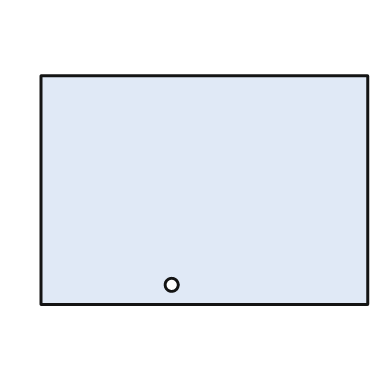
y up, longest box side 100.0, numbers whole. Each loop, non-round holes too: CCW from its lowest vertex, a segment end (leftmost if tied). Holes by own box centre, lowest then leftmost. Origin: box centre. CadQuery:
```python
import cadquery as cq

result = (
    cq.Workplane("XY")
    .moveTo(-50.0, -35.0)
    .lineTo(50.0, -35.0)
    .lineTo(50.0, 35.0)
    .lineTo(-50.0, 35.0)
    .close()
    .moveTo(-10.0, -29.0)
    .circle(2.0)
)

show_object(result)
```